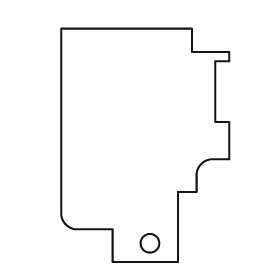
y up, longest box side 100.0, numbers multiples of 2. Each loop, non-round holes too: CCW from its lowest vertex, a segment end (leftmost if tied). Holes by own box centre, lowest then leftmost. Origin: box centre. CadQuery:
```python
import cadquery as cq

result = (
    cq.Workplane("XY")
    .moveTo(-14.0, -50.0)
    .lineTo(14.0, -50.0)
    .lineTo(14.0, -20.0)
    .lineTo(22.0, -20.0)
    .lineTo(22.0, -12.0)
    .threePointArc((24.0, -8.0), (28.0, -6.0))
    .lineTo(36.0, -6.0)
    .lineTo(36.0, 10.0)
    .lineTo(30.0, 10.0)
    .lineTo(30.0, 36.0)
    .lineTo(36.0, 36.0)
    .lineTo(36.0, 40.0)
    .lineTo(20.0, 40.0)
    .lineTo(20.0, 50.0)
    .lineTo(-36.0, 50.0)
    .lineTo(-36.0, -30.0)
    .threePointArc((-34.0, -34.0), (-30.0, -36.0))
    .lineTo(-14.0, -36.0)
    .close()
    .moveTo(2.0, -42.0)
    .circle(4.0)
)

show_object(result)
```